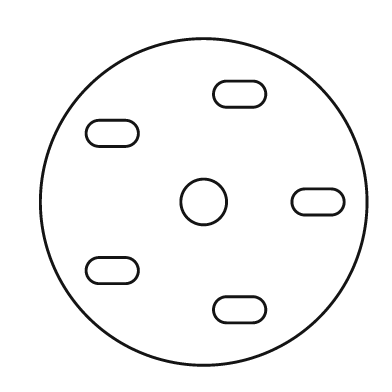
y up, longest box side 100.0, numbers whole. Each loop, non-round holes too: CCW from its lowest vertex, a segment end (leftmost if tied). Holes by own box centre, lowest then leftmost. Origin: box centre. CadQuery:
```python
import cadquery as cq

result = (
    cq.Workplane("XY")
    .moveTo(0.0, 0.0)
    .circle(50.0)
    .moveTo(7.0, -37.0)
    .lineTo(15.0, -37.0)
    .threePointArc((19.0, -33.0), (15.0, -29.0))
    .lineTo(7.0, -29.0)
    .threePointArc((3.0, -33.0), (7.0, -37.0))
    .close()
    .moveTo(-32.0, -25.0)
    .lineTo(-24.0, -25.0)
    .threePointArc((-20.0, -21.0), (-24.0, -17.0))
    .lineTo(-32.0, -17.0)
    .threePointArc((-36.0, -21.0), (-32.0, -25.0))
    .close()
    .moveTo(0.0, 0.0)
    .circle(7.0)
    .moveTo(31.0, -4.0)
    .lineTo(39.0, -4.0)
    .threePointArc((43.0, 0.0), (39.0, 4.0))
    .lineTo(31.0, 4.0)
    .threePointArc((27.0, 0.0), (31.0, -4.0))
    .close()
    .moveTo(-32.0, 17.0)
    .lineTo(-24.0, 17.0)
    .threePointArc((-20.0, 21.0), (-24.0, 25.0))
    .lineTo(-32.0, 25.0)
    .threePointArc((-36.0, 21.0), (-32.0, 17.0))
    .close()
    .moveTo(7.0, 29.0)
    .lineTo(15.0, 29.0)
    .threePointArc((19.0, 33.0), (15.0, 37.0))
    .lineTo(7.0, 37.0)
    .threePointArc((3.0, 33.0), (7.0, 29.0))
    .close()
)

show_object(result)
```